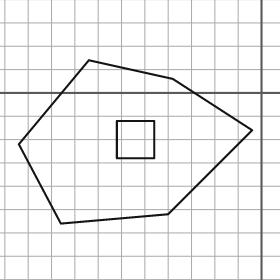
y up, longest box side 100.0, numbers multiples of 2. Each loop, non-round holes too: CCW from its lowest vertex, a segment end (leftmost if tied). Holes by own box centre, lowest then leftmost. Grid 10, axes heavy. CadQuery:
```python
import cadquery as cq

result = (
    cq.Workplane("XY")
    .moveTo(-86.0, -56.0)
    .lineTo(-40.0, -52.0)
    .lineTo(-4.0, -16.0)
    .lineTo(-38.0, 6.0)
    .lineTo(-74.0, 14.0)
    .lineTo(-104.0, -22.0)
    .close()
    .moveTo(-62.0, -28.0)
    .lineTo(-46.0, -28.0)
    .lineTo(-46.0, -12.0)
    .lineTo(-62.0, -12.0)
    .close()
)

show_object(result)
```